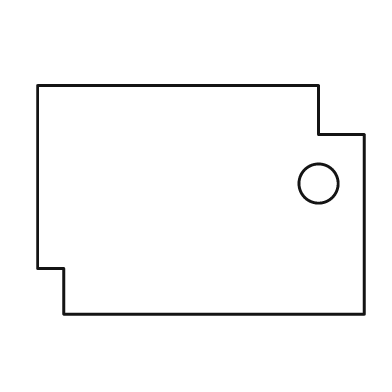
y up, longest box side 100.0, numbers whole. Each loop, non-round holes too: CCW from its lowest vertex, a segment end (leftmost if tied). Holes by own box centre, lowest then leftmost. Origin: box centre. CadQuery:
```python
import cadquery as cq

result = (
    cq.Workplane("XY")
    .moveTo(-42.0, -35.0)
    .lineTo(50.0, -35.0)
    .lineTo(50.0, 20.0)
    .lineTo(36.0, 20.0)
    .lineTo(36.0, 35.0)
    .lineTo(-50.0, 35.0)
    .lineTo(-50.0, -21.0)
    .lineTo(-42.0, -21.0)
    .close()
    .moveTo(36.0, 5.0)
    .circle(6.0)
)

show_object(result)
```